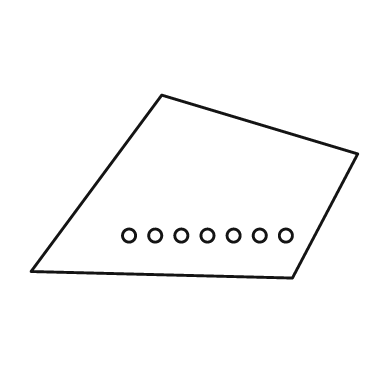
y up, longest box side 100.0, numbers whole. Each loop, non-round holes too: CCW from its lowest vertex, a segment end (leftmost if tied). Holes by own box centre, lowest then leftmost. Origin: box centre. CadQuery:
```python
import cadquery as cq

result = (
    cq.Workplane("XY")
    .moveTo(30.0, -28.0)
    .lineTo(50.0, 10.0)
    .lineTo(-10.0, 28.0)
    .lineTo(-50.0, -26.0)
    .close()
    .moveTo(-20.0, -15.0)
    .circle(2.0)
    .moveTo(-12.0, -15.0)
    .circle(2.0)
    .moveTo(-4.0, -15.0)
    .circle(2.0)
    .moveTo(4.0, -15.0)
    .circle(2.0)
    .moveTo(12.0, -15.0)
    .circle(2.0)
    .moveTo(20.0, -15.0)
    .circle(2.0)
    .moveTo(28.0, -15.0)
    .circle(2.0)
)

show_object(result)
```